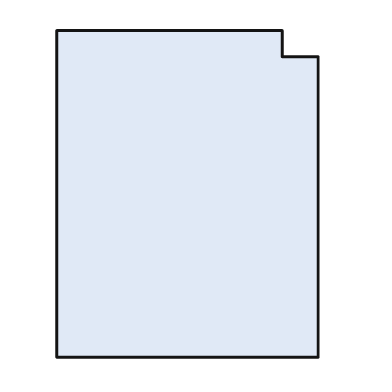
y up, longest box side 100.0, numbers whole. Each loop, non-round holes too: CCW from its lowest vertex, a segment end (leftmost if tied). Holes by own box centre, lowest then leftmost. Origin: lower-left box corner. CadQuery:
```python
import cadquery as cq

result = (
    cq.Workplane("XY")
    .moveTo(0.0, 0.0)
    .lineTo(80.0, 0.0)
    .lineTo(80.0, 92.0)
    .lineTo(69.0, 92.0)
    .lineTo(69.0, 100.0)
    .lineTo(0.0, 100.0)
    .close()
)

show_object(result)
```